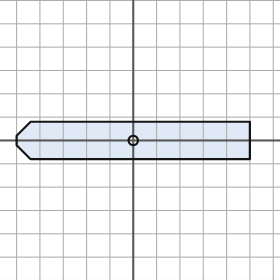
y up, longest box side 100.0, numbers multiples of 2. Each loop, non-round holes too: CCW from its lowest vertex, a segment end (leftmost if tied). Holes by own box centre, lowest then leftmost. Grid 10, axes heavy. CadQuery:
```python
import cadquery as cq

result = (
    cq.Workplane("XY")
    .moveTo(-44.0, -8.0)
    .lineTo(50.0, -8.0)
    .lineTo(50.0, 8.0)
    .lineTo(-44.0, 8.0)
    .lineTo(-50.0, 2.0)
    .lineTo(-50.0, -2.0)
    .close()
    .moveTo(0.0, 0.0)
    .circle(2.0)
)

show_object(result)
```